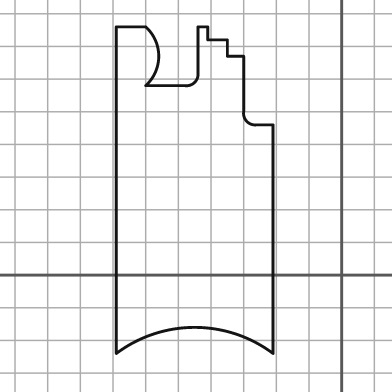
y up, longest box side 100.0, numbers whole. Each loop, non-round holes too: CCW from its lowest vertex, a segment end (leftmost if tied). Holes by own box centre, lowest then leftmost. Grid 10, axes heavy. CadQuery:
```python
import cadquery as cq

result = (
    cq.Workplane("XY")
    .moveTo(-69.0, -24.0)
    .threePointArc((-45.0, -16.0), (-21.0, -24.0))
    .lineTo(-21.0, 46.0)
    .lineTo(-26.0, 46.0)
    .threePointArc((-29.0, 47.0), (-30.0, 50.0))
    .lineTo(-30.0, 67.0)
    .lineTo(-35.0, 67.0)
    .lineTo(-35.0, 72.0)
    .lineTo(-41.0, 72.0)
    .lineTo(-41.0, 76.0)
    .lineTo(-44.0, 76.0)
    .lineTo(-44.0, 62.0)
    .threePointArc((-45.0, 59.0), (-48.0, 58.0))
    .lineTo(-60.0, 58.0)
    .threePointArc((-56.0, 67.0), (-60.0, 76.0))
    .lineTo(-69.0, 76.0)
    .close()
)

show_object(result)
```